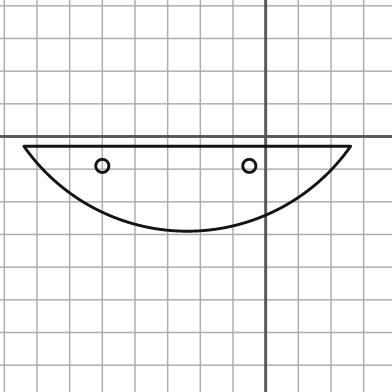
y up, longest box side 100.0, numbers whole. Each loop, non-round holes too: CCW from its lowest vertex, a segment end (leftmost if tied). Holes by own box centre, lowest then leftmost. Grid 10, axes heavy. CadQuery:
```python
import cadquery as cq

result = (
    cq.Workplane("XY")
    .moveTo(-74.0, -3.0)
    .threePointArc((-24.0, -29.0), (26.0, -3.0))
    .close()
    .moveTo(-50.0, -9.0)
    .circle(2.0)
    .moveTo(-5.0, -9.0)
    .circle(2.0)
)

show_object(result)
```